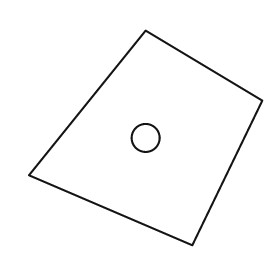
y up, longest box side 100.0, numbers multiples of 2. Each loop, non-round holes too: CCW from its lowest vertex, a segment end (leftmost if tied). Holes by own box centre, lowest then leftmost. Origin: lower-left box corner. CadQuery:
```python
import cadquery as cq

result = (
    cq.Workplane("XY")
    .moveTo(70.0, 0.0)
    .lineTo(100.0, 62.0)
    .lineTo(50.0, 92.0)
    .lineTo(0.0, 30.0)
    .close()
    .moveTo(50.0, 46.0)
    .circle(6.0)
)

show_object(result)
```